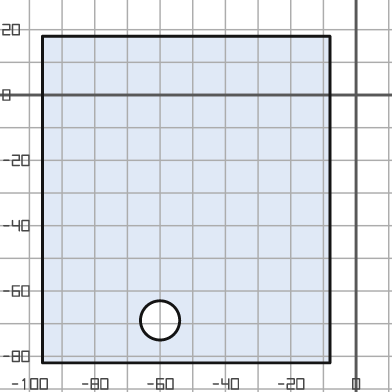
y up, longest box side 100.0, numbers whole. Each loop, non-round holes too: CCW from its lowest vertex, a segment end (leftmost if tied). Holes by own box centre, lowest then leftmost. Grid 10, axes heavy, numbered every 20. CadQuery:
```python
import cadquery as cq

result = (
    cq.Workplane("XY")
    .moveTo(-96.0, -82.0)
    .lineTo(-8.0, -82.0)
    .lineTo(-8.0, 18.0)
    .lineTo(-96.0, 18.0)
    .close()
    .moveTo(-60.0, -69.0)
    .circle(6.0)
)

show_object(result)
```